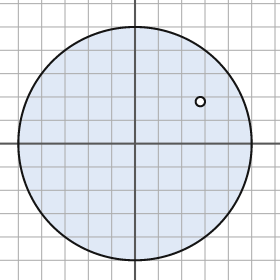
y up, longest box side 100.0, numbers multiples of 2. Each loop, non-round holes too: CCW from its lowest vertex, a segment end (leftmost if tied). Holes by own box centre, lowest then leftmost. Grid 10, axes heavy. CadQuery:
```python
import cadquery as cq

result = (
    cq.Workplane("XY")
    .moveTo(0.0, 0.0)
    .circle(50.0)
    .moveTo(28.0, 18.0)
    .circle(2.0)
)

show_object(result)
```